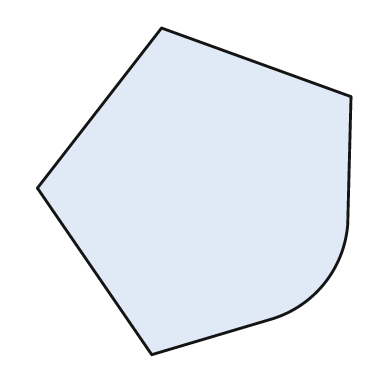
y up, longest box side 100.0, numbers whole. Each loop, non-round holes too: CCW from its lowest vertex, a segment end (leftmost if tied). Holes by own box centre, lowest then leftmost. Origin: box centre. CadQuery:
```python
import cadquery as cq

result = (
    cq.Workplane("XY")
    .moveTo(-13.0, -50.0)
    .lineTo(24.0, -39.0)
    .threePointArc((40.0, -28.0), (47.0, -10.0))
    .lineTo(48.0, 29.0)
    .lineTo(-10.0, 50.0)
    .lineTo(-48.0, 1.0)
    .close()
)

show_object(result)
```